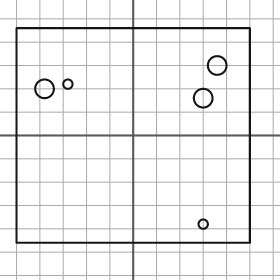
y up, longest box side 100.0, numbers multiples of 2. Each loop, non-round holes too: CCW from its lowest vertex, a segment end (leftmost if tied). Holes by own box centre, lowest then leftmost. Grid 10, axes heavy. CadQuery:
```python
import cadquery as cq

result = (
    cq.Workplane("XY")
    .moveTo(-50.0, -46.0)
    .lineTo(50.0, -46.0)
    .lineTo(50.0, 46.0)
    .lineTo(-50.0, 46.0)
    .close()
    .moveTo(30.0, -38.0)
    .circle(2.0)
    .moveTo(30.0, 16.0)
    .circle(4.0)
    .moveTo(-38.0, 20.0)
    .circle(4.0)
    .moveTo(-28.0, 22.0)
    .circle(2.0)
    .moveTo(36.0, 30.0)
    .circle(4.0)
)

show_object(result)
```